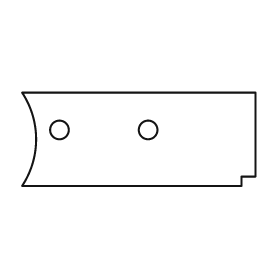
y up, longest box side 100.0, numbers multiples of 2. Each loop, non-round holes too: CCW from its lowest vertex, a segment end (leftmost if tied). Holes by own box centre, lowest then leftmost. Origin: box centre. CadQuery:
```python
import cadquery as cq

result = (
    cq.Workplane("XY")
    .moveTo(-50.0, -20.0)
    .lineTo(44.0, -20.0)
    .lineTo(44.0, -16.0)
    .lineTo(50.0, -16.0)
    .lineTo(50.0, 20.0)
    .lineTo(-50.0, 20.0)
    .threePointArc((-44.0, 0.0), (-50.0, -20.0))
    .close()
    .moveTo(-34.0, 4.0)
    .circle(4.0)
    .moveTo(4.0, 4.0)
    .circle(4.0)
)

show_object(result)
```